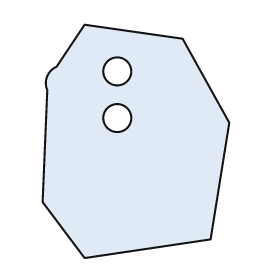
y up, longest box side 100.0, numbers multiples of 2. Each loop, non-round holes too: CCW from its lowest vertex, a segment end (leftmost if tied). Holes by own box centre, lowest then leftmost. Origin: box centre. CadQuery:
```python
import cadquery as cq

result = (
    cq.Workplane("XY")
    .moveTo(-22.0, -50.0)
    .lineTo(32.0, -42.0)
    .lineTo(40.0, 8.0)
    .lineTo(20.0, 44.0)
    .lineTo(-22.0, 50.0)
    .lineTo(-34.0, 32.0)
    .threePointArc((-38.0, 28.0), (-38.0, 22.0))
    .lineTo(-40.0, -26.0)
    .close()
    .moveTo(-8.0, 10.0)
    .circle(6.0)
    .moveTo(-8.0, 30.0)
    .circle(6.0)
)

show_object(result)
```